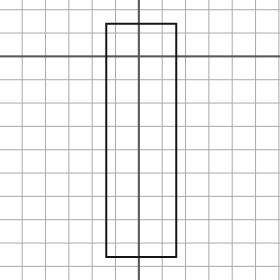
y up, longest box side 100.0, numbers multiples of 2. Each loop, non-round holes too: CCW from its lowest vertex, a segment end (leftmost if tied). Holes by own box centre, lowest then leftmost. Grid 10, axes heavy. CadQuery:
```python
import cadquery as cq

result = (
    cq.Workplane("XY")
    .moveTo(-14.0, -86.0)
    .lineTo(16.0, -86.0)
    .lineTo(16.0, 14.0)
    .lineTo(-14.0, 14.0)
    .close()
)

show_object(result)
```